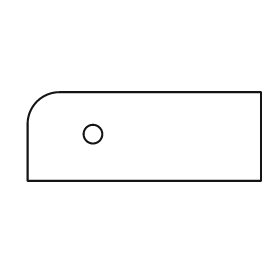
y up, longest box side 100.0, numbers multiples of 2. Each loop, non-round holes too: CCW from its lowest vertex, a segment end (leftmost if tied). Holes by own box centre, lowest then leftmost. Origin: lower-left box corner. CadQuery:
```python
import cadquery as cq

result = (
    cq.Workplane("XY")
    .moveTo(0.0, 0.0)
    .lineTo(100.0, 0.0)
    .lineTo(100.0, 38.0)
    .lineTo(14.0, 38.0)
    .threePointArc((4.0, 34.0), (0.0, 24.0))
    .close()
    .moveTo(28.0, 20.0)
    .circle(4.0)
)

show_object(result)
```